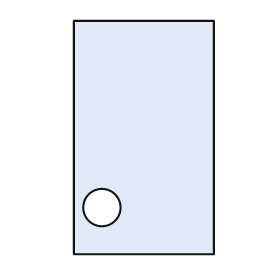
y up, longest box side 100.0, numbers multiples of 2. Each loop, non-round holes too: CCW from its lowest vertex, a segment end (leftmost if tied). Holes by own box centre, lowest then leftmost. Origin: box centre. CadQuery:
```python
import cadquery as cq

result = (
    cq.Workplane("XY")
    .moveTo(-30.0, -50.0)
    .lineTo(30.0, -50.0)
    .lineTo(30.0, 50.0)
    .lineTo(-30.0, 50.0)
    .close()
    .moveTo(-18.0, -30.0)
    .circle(8.0)
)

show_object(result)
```